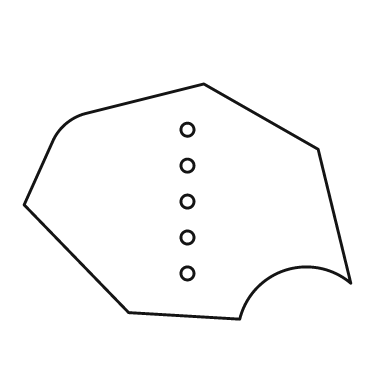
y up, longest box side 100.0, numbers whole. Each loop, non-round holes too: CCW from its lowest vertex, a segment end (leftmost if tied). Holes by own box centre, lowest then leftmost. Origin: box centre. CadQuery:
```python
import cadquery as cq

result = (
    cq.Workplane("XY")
    .moveTo(16.0, -36.0)
    .threePointArc((30.0, -21.0), (50.0, -25.0))
    .lineTo(40.0, 16.0)
    .lineTo(5.0, 36.0)
    .lineTo(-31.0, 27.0)
    .threePointArc((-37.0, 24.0), (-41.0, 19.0))
    .lineTo(-50.0, -1.0)
    .lineTo(-18.0, -34.0)
    .close()
    .moveTo(0.0, -22.0)
    .circle(2.0)
    .moveTo(0.0, -11.0)
    .circle(2.0)
    .moveTo(0.0, 0.0)
    .circle(2.0)
    .moveTo(0.0, 11.0)
    .circle(2.0)
    .moveTo(0.0, 22.0)
    .circle(2.0)
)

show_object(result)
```